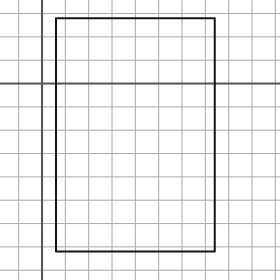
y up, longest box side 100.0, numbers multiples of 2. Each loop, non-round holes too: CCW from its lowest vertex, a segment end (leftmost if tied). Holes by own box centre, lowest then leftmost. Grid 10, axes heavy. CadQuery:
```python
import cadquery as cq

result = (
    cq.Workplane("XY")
    .moveTo(6.0, -72.0)
    .lineTo(74.0, -72.0)
    .lineTo(74.0, 28.0)
    .lineTo(6.0, 28.0)
    .close()
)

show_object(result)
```